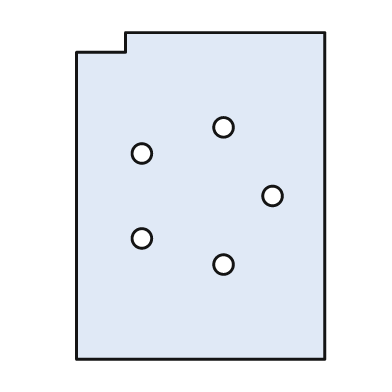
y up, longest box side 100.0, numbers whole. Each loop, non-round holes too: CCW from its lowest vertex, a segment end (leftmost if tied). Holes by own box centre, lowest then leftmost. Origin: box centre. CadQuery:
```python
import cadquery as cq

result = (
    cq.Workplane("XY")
    .moveTo(-38.0, -50.0)
    .lineTo(38.0, -50.0)
    .lineTo(38.0, 50.0)
    .lineTo(-23.0, 50.0)
    .lineTo(-23.0, 44.0)
    .lineTo(-38.0, 44.0)
    .close()
    .moveTo(7.0, -21.0)
    .circle(3.0)
    .moveTo(-18.0, -13.0)
    .circle(3.0)
    .moveTo(22.0, 0.0)
    .circle(3.0)
    .moveTo(-18.0, 13.0)
    .circle(3.0)
    .moveTo(7.0, 21.0)
    .circle(3.0)
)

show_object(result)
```